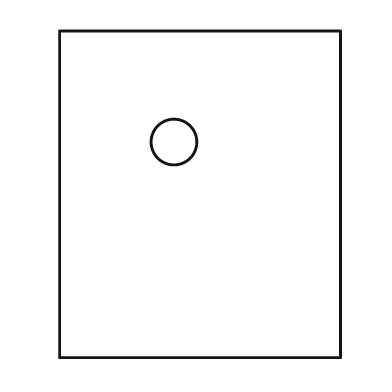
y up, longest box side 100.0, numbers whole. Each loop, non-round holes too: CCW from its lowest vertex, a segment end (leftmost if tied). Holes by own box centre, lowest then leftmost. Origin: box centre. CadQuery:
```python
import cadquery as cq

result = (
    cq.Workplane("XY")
    .moveTo(-43.0, -50.0)
    .lineTo(43.0, -50.0)
    .lineTo(43.0, 50.0)
    .lineTo(-43.0, 50.0)
    .close()
    .moveTo(-8.0, 16.0)
    .circle(7.0)
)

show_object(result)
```